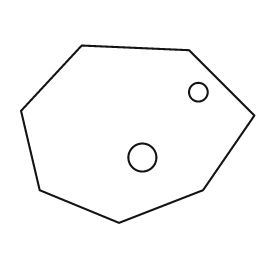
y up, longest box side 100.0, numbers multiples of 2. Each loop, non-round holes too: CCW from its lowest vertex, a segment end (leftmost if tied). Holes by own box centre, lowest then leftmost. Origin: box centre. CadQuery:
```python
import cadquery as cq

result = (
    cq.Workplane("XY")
    .moveTo(-8.0, -38.0)
    .lineTo(28.0, -24.0)
    .lineTo(50.0, 8.0)
    .lineTo(22.0, 36.0)
    .lineTo(-24.0, 38.0)
    .lineTo(-50.0, 10.0)
    .lineTo(-42.0, -24.0)
    .close()
    .moveTo(2.0, -10.0)
    .circle(6.0)
    .moveTo(26.0, 18.0)
    .circle(4.0)
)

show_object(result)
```